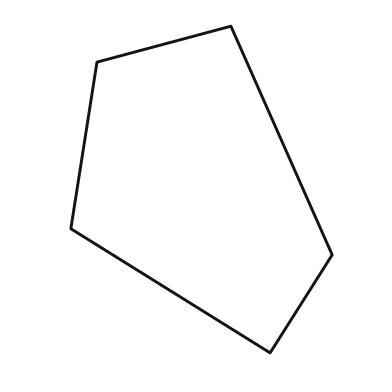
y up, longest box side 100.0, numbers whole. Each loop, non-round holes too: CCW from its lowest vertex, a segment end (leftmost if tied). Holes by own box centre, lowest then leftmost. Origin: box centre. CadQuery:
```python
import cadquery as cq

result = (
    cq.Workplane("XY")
    .moveTo(21.0, -50.0)
    .lineTo(40.0, -20.0)
    .lineTo(9.0, 50.0)
    .lineTo(-32.0, 39.0)
    .lineTo(-40.0, -12.0)
    .close()
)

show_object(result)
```